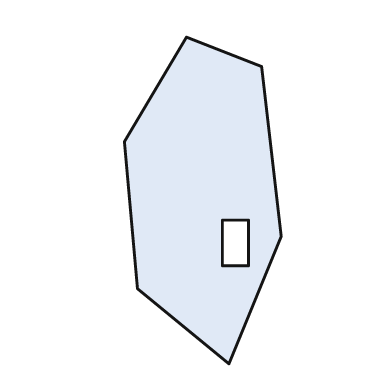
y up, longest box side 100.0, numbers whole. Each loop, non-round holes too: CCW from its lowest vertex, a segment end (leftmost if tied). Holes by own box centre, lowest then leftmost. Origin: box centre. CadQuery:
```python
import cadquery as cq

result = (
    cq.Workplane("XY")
    .moveTo(8.0, -50.0)
    .lineTo(24.0, -11.0)
    .lineTo(18.0, 41.0)
    .lineTo(-5.0, 50.0)
    .lineTo(-24.0, 18.0)
    .lineTo(-20.0, -27.0)
    .close()
    .moveTo(6.0, -20.0)
    .lineTo(14.0, -20.0)
    .lineTo(14.0, -6.0)
    .lineTo(6.0, -6.0)
    .close()
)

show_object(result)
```